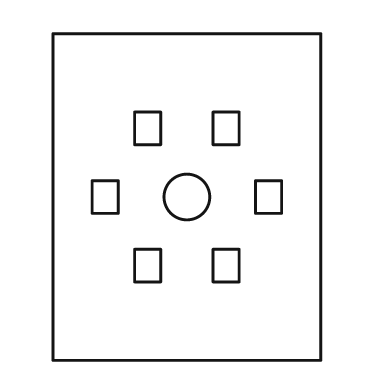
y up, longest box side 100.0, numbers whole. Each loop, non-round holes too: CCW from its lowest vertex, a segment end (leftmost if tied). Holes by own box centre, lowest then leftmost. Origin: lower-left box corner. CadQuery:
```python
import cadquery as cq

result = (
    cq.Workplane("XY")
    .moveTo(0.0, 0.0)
    .lineTo(82.0, 0.0)
    .lineTo(82.0, 100.0)
    .lineTo(0.0, 100.0)
    .close()
    .moveTo(25.0, 24.0)
    .lineTo(33.0, 24.0)
    .lineTo(33.0, 34.0)
    .lineTo(25.0, 34.0)
    .close()
    .moveTo(49.0, 24.0)
    .lineTo(57.0, 24.0)
    .lineTo(57.0, 34.0)
    .lineTo(49.0, 34.0)
    .close()
    .moveTo(12.0, 45.0)
    .lineTo(20.0, 45.0)
    .lineTo(20.0, 55.0)
    .lineTo(12.0, 55.0)
    .close()
    .moveTo(41.0, 50.0)
    .circle(7.0)
    .moveTo(62.0, 45.0)
    .lineTo(70.0, 45.0)
    .lineTo(70.0, 55.0)
    .lineTo(62.0, 55.0)
    .close()
    .moveTo(25.0, 66.0)
    .lineTo(33.0, 66.0)
    .lineTo(33.0, 76.0)
    .lineTo(25.0, 76.0)
    .close()
    .moveTo(49.0, 66.0)
    .lineTo(57.0, 66.0)
    .lineTo(57.0, 76.0)
    .lineTo(49.0, 76.0)
    .close()
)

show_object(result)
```